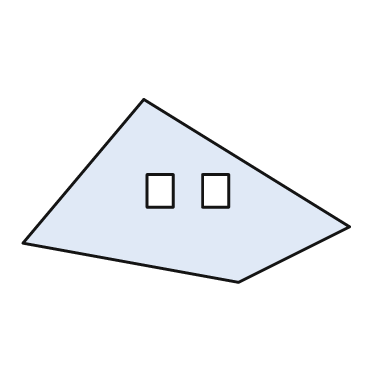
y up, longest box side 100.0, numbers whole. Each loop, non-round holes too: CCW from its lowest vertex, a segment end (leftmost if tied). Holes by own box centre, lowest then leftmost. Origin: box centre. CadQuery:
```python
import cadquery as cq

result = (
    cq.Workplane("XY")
    .moveTo(16.0, -28.0)
    .lineTo(50.0, -11.0)
    .lineTo(-13.0, 28.0)
    .lineTo(-50.0, -16.0)
    .close()
    .moveTo(-12.0, -5.0)
    .lineTo(-4.0, -5.0)
    .lineTo(-4.0, 5.0)
    .lineTo(-12.0, 5.0)
    .close()
    .moveTo(5.0, -5.0)
    .lineTo(13.0, -5.0)
    .lineTo(13.0, 5.0)
    .lineTo(5.0, 5.0)
    .close()
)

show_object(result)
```